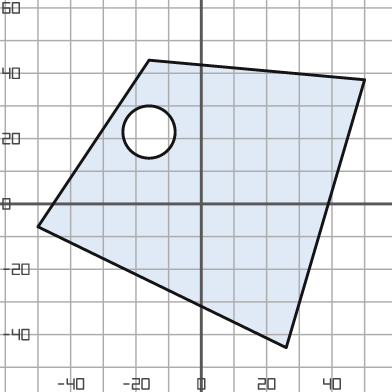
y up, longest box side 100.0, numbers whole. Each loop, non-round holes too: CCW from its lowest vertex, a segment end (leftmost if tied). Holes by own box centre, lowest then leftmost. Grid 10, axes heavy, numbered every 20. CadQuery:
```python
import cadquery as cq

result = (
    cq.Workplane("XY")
    .moveTo(26.0, -44.0)
    .lineTo(50.0, 38.0)
    .lineTo(-16.0, 44.0)
    .lineTo(-50.0, -7.0)
    .close()
    .moveTo(-16.0, 22.0)
    .circle(8.0)
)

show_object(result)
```